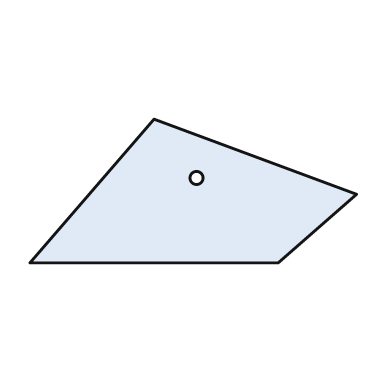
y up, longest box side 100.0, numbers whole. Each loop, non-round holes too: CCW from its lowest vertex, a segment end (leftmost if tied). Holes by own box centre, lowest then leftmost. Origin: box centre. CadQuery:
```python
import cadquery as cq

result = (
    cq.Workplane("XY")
    .moveTo(-50.0, -22.0)
    .lineTo(26.0, -22.0)
    .lineTo(50.0, -1.0)
    .lineTo(-12.0, 22.0)
    .close()
    .moveTo(1.0, 4.0)
    .circle(2.0)
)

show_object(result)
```